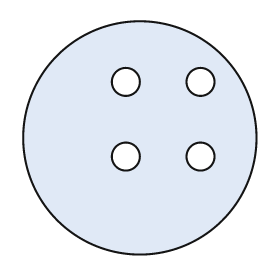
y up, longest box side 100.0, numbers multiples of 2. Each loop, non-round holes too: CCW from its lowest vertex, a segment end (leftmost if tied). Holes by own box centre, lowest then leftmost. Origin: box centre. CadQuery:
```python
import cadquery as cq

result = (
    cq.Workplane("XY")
    .moveTo(0.0, 0.0)
    .circle(50.0)
    .moveTo(-6.0, -8.0)
    .circle(6.0)
    .moveTo(26.0, -8.0)
    .circle(6.0)
    .moveTo(-6.0, 24.0)
    .circle(6.0)
    .moveTo(26.0, 24.0)
    .circle(6.0)
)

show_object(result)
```